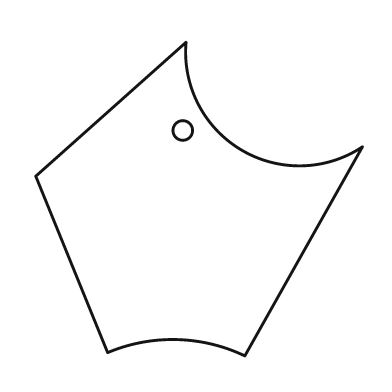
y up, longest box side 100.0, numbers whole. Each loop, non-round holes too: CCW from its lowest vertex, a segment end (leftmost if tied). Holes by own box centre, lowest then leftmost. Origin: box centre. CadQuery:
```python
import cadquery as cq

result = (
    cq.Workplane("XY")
    .moveTo(14.0, -48.0)
    .lineTo(50.0, 16.0)
    .threePointArc((13.0, 15.0), (-4.0, 48.0))
    .lineTo(-50.0, 7.0)
    .lineTo(-28.0, -47.0)
    .threePointArc((-7.0, -43.0), (14.0, -48.0))
    .close()
    .moveTo(-5.0, 21.0)
    .circle(3.0)
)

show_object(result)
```